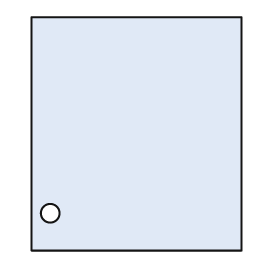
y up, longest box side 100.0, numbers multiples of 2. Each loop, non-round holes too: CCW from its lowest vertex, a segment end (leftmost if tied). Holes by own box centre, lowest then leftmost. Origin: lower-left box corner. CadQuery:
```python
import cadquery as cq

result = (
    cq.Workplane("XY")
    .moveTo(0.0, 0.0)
    .lineTo(90.0, 0.0)
    .lineTo(90.0, 100.0)
    .lineTo(0.0, 100.0)
    .close()
    .moveTo(8.0, 16.0)
    .circle(4.0)
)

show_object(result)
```